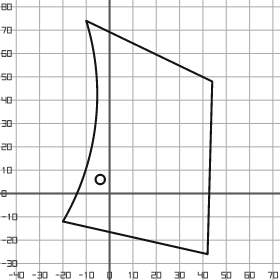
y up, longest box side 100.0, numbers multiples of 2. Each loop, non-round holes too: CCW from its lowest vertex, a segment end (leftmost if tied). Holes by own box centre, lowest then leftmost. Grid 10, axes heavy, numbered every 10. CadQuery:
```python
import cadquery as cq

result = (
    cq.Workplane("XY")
    .moveTo(42.0, -26.0)
    .lineTo(44.0, 48.0)
    .lineTo(-10.0, 74.0)
    .threePointArc((-6.0, 30.0), (-20.0, -12.0))
    .close()
    .moveTo(-4.0, 6.0)
    .circle(2.0)
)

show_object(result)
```